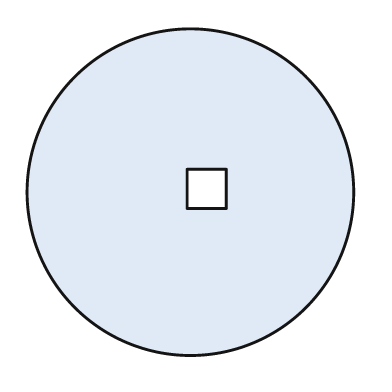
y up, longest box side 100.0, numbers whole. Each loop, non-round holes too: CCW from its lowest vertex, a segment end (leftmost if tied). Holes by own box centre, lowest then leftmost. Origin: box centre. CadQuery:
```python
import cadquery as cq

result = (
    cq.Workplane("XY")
    .moveTo(0.0, 0.0)
    .circle(50.0)
    .moveTo(-1.0, -5.0)
    .lineTo(11.0, -5.0)
    .lineTo(11.0, 7.0)
    .lineTo(-1.0, 7.0)
    .close()
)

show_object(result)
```